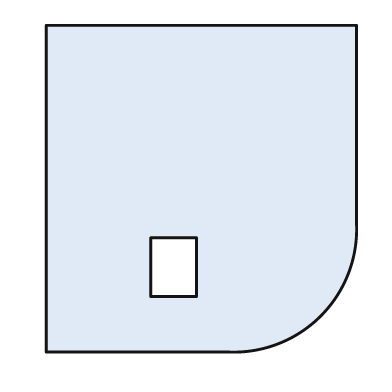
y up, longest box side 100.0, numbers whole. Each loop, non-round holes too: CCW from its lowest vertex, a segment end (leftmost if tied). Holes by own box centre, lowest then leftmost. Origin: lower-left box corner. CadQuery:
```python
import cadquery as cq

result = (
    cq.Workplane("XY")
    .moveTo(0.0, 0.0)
    .lineTo(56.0, 0.0)
    .threePointArc((84.0, 11.0), (95.0, 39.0))
    .lineTo(95.0, 100.0)
    .lineTo(0.0, 100.0)
    .close()
    .moveTo(32.0, 17.0)
    .lineTo(46.0, 17.0)
    .lineTo(46.0, 35.0)
    .lineTo(32.0, 35.0)
    .close()
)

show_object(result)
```